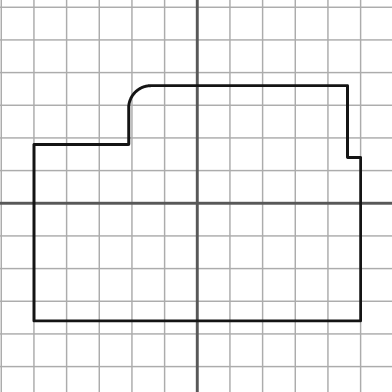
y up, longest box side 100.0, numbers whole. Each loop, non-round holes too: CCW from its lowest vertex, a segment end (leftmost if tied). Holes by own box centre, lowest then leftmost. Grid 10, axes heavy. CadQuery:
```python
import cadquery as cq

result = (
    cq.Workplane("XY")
    .moveTo(-50.0, -36.0)
    .lineTo(50.0, -36.0)
    .lineTo(50.0, 14.0)
    .lineTo(46.0, 14.0)
    .lineTo(46.0, 36.0)
    .lineTo(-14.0, 36.0)
    .threePointArc((-19.0, 34.0), (-21.0, 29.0))
    .lineTo(-21.0, 18.0)
    .lineTo(-50.0, 18.0)
    .close()
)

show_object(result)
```